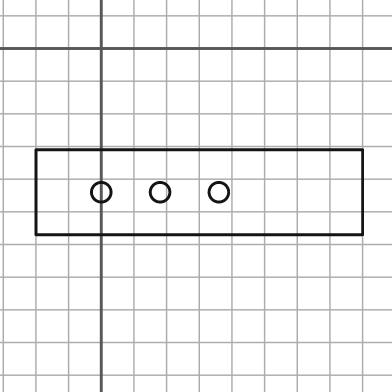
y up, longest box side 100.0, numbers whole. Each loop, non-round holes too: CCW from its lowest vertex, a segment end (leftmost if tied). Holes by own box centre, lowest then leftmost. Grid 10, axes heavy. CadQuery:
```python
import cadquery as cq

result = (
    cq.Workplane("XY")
    .moveTo(-20.0, -57.0)
    .lineTo(80.0, -57.0)
    .lineTo(80.0, -31.0)
    .lineTo(-20.0, -31.0)
    .close()
    .moveTo(0.0, -44.0)
    .circle(3.0)
    .moveTo(18.0, -44.0)
    .circle(3.0)
    .moveTo(36.0, -44.0)
    .circle(3.0)
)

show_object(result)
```